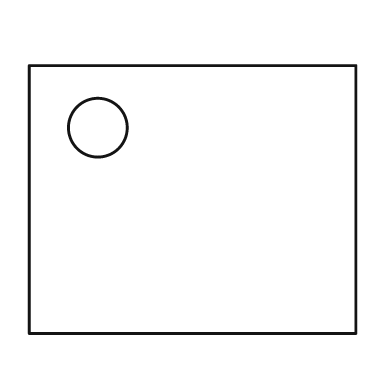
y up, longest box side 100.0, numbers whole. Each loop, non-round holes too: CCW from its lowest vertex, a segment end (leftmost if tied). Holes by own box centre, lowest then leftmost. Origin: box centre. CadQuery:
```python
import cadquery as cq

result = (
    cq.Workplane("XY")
    .moveTo(-50.0, -41.0)
    .lineTo(50.0, -41.0)
    .lineTo(50.0, 41.0)
    .lineTo(-50.0, 41.0)
    .close()
    .moveTo(-29.0, 22.0)
    .circle(9.0)
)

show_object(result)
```